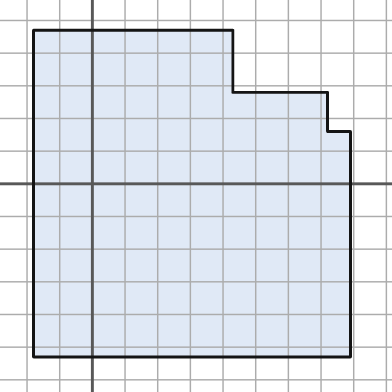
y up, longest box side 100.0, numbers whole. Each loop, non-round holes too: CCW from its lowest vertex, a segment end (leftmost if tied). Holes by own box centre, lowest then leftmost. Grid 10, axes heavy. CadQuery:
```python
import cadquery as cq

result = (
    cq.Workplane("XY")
    .moveTo(-18.0, -53.0)
    .lineTo(79.0, -53.0)
    .lineTo(79.0, 16.0)
    .lineTo(72.0, 16.0)
    .lineTo(72.0, 28.0)
    .lineTo(43.0, 28.0)
    .lineTo(43.0, 47.0)
    .lineTo(-18.0, 47.0)
    .close()
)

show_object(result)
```